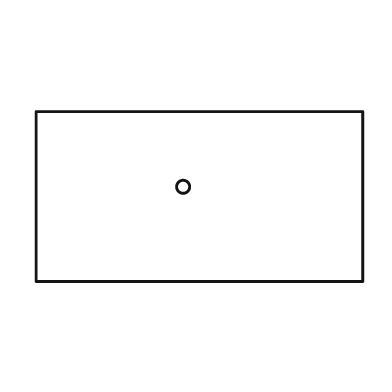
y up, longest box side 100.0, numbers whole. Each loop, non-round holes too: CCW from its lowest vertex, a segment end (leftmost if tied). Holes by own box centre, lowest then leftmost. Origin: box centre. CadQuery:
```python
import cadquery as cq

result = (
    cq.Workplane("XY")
    .moveTo(-50.0, -26.0)
    .lineTo(50.0, -26.0)
    .lineTo(50.0, 26.0)
    .lineTo(-50.0, 26.0)
    .close()
    .moveTo(-5.0, 3.0)
    .circle(2.0)
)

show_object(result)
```